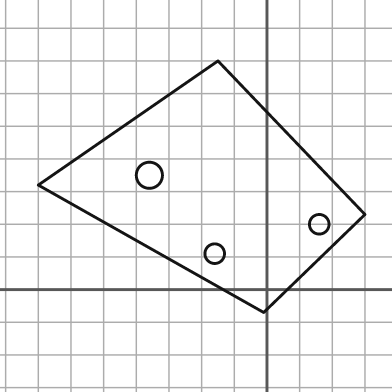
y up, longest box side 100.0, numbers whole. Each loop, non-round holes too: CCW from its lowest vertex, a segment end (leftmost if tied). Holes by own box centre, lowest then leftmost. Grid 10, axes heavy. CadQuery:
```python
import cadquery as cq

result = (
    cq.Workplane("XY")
    .moveTo(-1.0, -7.0)
    .lineTo(30.0, 23.0)
    .lineTo(-15.0, 70.0)
    .lineTo(-70.0, 32.0)
    .close()
    .moveTo(-16.0, 11.0)
    .circle(3.0)
    .moveTo(16.0, 20.0)
    .circle(3.0)
    .moveTo(-36.0, 35.0)
    .circle(4.0)
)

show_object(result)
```